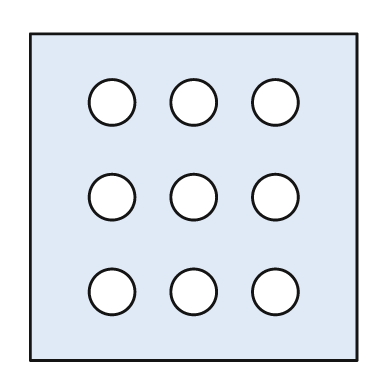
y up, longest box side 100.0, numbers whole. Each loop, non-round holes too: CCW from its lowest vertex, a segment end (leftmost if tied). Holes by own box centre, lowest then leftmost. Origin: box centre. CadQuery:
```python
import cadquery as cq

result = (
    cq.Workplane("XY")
    .moveTo(-50.0, -50.0)
    .lineTo(50.0, -50.0)
    .lineTo(50.0, 50.0)
    .lineTo(-50.0, 50.0)
    .close()
    .moveTo(-25.0, -29.0)
    .circle(7.0)
    .moveTo(0.0, -29.0)
    .circle(7.0)
    .moveTo(25.0, -29.0)
    .circle(7.0)
    .moveTo(-25.0, 0.0)
    .circle(7.0)
    .moveTo(0.0, 0.0)
    .circle(7.0)
    .moveTo(25.0, 0.0)
    .circle(7.0)
    .moveTo(-25.0, 29.0)
    .circle(7.0)
    .moveTo(0.0, 29.0)
    .circle(7.0)
    .moveTo(25.0, 29.0)
    .circle(7.0)
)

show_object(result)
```